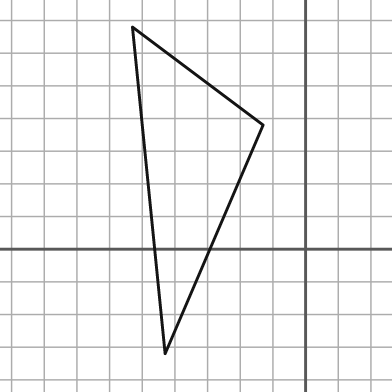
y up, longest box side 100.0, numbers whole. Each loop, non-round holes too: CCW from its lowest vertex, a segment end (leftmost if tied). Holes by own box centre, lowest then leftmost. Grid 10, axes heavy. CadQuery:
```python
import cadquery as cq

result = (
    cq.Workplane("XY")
    .moveTo(-43.0, -32.0)
    .lineTo(-13.0, 38.0)
    .lineTo(-53.0, 68.0)
    .close()
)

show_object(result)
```